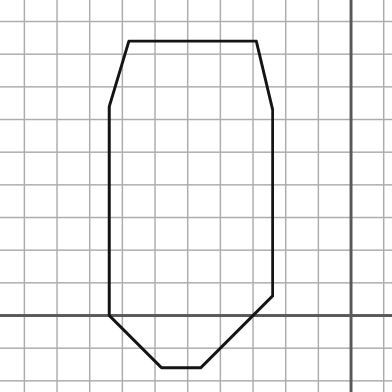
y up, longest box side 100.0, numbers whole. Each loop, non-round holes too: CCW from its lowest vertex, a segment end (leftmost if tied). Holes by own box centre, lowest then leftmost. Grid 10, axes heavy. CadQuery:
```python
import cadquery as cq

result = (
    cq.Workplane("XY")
    .moveTo(-58.0, -16.0)
    .lineTo(-46.0, -16.0)
    .lineTo(-24.0, 6.0)
    .lineTo(-24.0, 63.0)
    .lineTo(-29.0, 84.0)
    .lineTo(-68.0, 84.0)
    .lineTo(-74.0, 64.0)
    .lineTo(-74.0, 0.0)
    .close()
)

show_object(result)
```